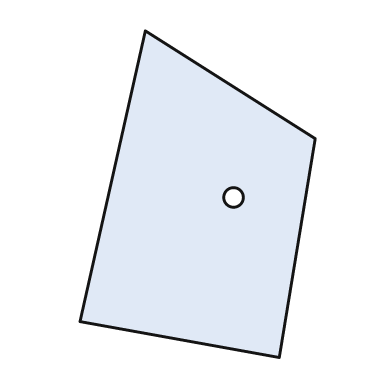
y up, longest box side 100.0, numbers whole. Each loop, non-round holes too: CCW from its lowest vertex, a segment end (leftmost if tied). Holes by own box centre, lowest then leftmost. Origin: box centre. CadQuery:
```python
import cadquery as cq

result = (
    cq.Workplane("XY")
    .moveTo(25.0, -50.0)
    .lineTo(36.0, 17.0)
    .lineTo(-16.0, 50.0)
    .lineTo(-36.0, -39.0)
    .close()
    .moveTo(11.0, -1.0)
    .circle(3.0)
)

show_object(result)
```